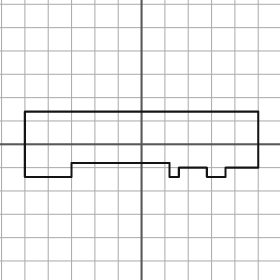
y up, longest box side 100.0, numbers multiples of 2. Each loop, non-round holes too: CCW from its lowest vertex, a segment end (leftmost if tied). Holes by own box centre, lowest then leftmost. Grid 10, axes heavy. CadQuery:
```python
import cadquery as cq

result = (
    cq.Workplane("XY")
    .moveTo(-50.0, -14.0)
    .lineTo(-30.0, -14.0)
    .lineTo(-30.0, -8.0)
    .lineTo(12.0, -8.0)
    .lineTo(12.0, -14.0)
    .lineTo(16.0, -14.0)
    .lineTo(16.0, -10.0)
    .lineTo(28.0, -10.0)
    .lineTo(28.0, -14.0)
    .lineTo(36.0, -14.0)
    .lineTo(36.0, -10.0)
    .lineTo(50.0, -10.0)
    .lineTo(50.0, 14.0)
    .lineTo(-50.0, 14.0)
    .close()
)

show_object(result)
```